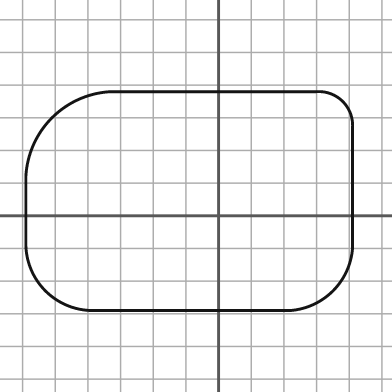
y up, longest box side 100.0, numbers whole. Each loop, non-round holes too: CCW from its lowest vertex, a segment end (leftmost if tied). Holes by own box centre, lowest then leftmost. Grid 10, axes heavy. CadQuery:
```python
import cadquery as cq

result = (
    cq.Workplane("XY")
    .moveTo(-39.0, -29.0)
    .lineTo(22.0, -29.0)
    .threePointArc((35.0, -23.0), (41.0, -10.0))
    .lineTo(41.0, 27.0)
    .threePointArc((38.0, 35.0), (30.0, 38.0))
    .lineTo(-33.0, 38.0)
    .threePointArc((-51.0, 30.0), (-59.0, 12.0))
    .lineTo(-59.0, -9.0)
    .threePointArc((-53.0, -23.0), (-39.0, -29.0))
    .close()
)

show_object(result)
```